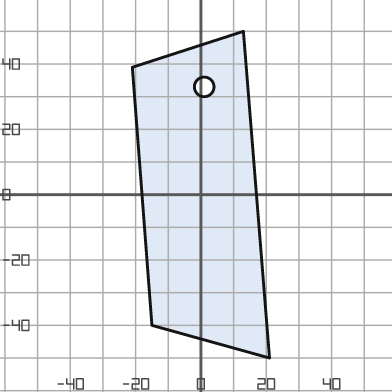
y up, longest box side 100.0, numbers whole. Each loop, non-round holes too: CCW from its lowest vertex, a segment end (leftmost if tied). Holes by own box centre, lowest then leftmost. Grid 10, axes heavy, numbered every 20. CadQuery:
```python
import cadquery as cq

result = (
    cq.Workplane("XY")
    .moveTo(21.0, -50.0)
    .lineTo(13.0, 50.0)
    .lineTo(-21.0, 39.0)
    .lineTo(-15.0, -40.0)
    .close()
    .moveTo(1.0, 33.0)
    .circle(3.0)
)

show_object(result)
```